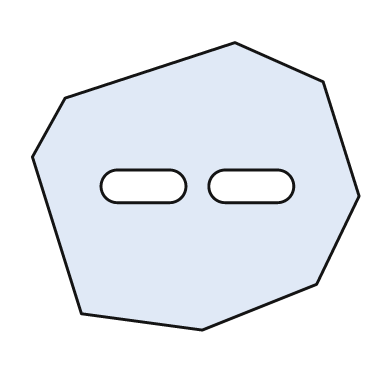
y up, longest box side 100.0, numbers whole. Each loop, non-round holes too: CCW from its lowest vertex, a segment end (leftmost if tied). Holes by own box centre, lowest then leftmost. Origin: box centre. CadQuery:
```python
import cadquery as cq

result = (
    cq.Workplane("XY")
    .moveTo(2.0, -44.0)
    .lineTo(37.0, -30.0)
    .lineTo(50.0, -3.0)
    .lineTo(39.0, 32.0)
    .lineTo(12.0, 44.0)
    .lineTo(-40.0, 27.0)
    .lineTo(-50.0, 9.0)
    .lineTo(-35.0, -39.0)
    .close()
    .moveTo(-24.0, -5.0)
    .lineTo(-8.0, -5.0)
    .threePointArc((-3.0, 0.0), (-8.0, 5.0))
    .lineTo(-24.0, 5.0)
    .threePointArc((-29.0, 0.0), (-24.0, -5.0))
    .close()
    .moveTo(9.0, -5.0)
    .lineTo(25.0, -5.0)
    .threePointArc((30.0, 0.0), (25.0, 5.0))
    .lineTo(9.0, 5.0)
    .threePointArc((4.0, 0.0), (9.0, -5.0))
    .close()
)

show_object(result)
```